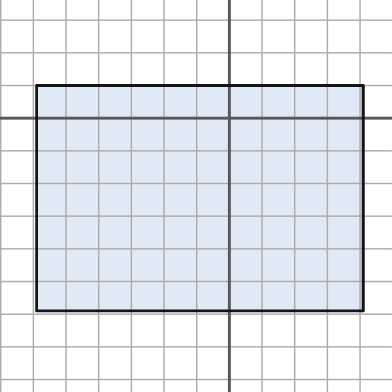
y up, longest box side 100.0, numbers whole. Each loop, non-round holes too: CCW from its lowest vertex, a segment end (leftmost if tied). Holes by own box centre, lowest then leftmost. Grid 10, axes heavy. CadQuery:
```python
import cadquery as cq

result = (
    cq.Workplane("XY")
    .moveTo(-59.0, -59.0)
    .lineTo(41.0, -59.0)
    .lineTo(41.0, 10.0)
    .lineTo(-59.0, 10.0)
    .close()
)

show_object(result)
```